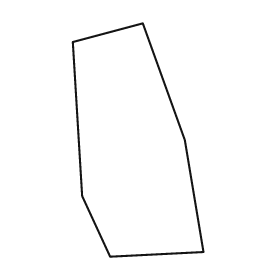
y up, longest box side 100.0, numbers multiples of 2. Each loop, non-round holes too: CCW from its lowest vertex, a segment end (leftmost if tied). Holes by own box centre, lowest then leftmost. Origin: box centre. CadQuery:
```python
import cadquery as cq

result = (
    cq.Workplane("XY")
    .moveTo(-12.0, -50.0)
    .lineTo(28.0, -48.0)
    .lineTo(20.0, 0.0)
    .lineTo(2.0, 50.0)
    .lineTo(-28.0, 42.0)
    .lineTo(-24.0, -24.0)
    .close()
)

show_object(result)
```